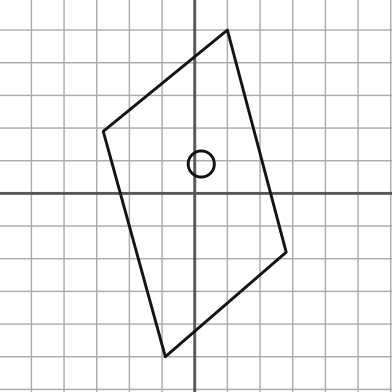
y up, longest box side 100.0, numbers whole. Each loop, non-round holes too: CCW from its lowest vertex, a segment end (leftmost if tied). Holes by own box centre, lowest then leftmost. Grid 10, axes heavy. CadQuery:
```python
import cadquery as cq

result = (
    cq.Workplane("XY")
    .moveTo(-9.0, -50.0)
    .lineTo(28.0, -18.0)
    .lineTo(10.0, 50.0)
    .lineTo(-28.0, 19.0)
    .close()
    .moveTo(2.0, 9.0)
    .circle(4.0)
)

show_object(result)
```